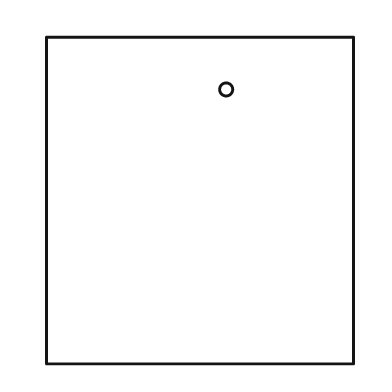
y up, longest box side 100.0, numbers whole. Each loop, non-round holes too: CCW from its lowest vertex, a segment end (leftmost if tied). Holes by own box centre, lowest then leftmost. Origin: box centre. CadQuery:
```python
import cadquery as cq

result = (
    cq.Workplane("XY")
    .moveTo(-47.0, -50.0)
    .lineTo(47.0, -50.0)
    .lineTo(47.0, 50.0)
    .lineTo(-47.0, 50.0)
    .close()
    .moveTo(8.0, 34.0)
    .circle(2.0)
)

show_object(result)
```